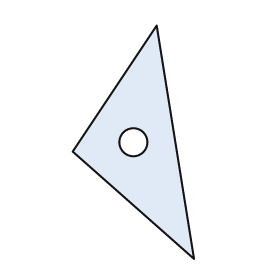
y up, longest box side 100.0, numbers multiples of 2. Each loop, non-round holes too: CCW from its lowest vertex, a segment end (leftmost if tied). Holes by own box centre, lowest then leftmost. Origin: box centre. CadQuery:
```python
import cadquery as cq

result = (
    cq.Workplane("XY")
    .moveTo(26.0, -50.0)
    .lineTo(10.0, 50.0)
    .lineTo(-26.0, -4.0)
    .close()
    .moveTo(0.0, 0.0)
    .circle(6.0)
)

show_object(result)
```